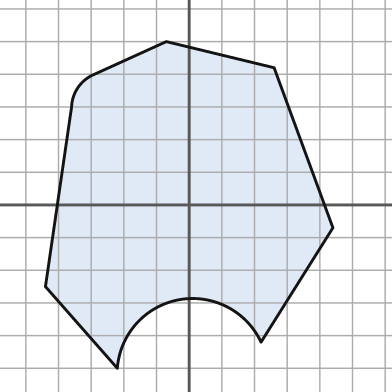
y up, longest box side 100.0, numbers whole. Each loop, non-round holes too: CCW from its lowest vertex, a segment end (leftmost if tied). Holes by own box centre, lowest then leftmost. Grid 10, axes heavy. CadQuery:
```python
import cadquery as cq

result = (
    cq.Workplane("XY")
    .moveTo(-22.0, -50.0)
    .threePointArc((-3.0, -29.0), (22.0, -42.0))
    .lineTo(44.0, -7.0)
    .lineTo(26.0, 42.0)
    .lineTo(-7.0, 50.0)
    .lineTo(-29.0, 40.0)
    .threePointArc((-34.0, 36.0), (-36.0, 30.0))
    .lineTo(-44.0, -25.0)
    .close()
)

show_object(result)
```